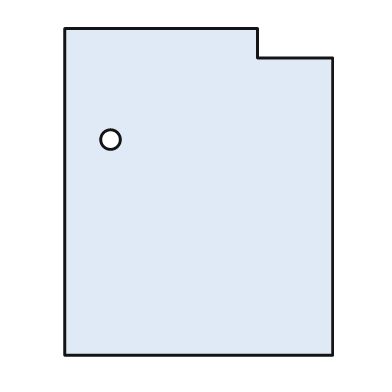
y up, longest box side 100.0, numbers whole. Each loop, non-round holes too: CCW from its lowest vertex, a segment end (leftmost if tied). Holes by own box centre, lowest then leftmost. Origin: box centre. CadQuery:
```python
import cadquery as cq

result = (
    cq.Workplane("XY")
    .moveTo(-41.0, -50.0)
    .lineTo(41.0, -50.0)
    .lineTo(41.0, 41.0)
    .lineTo(18.0, 41.0)
    .lineTo(18.0, 50.0)
    .lineTo(-41.0, 50.0)
    .close()
    .moveTo(-27.0, 16.0)
    .circle(3.0)
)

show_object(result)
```